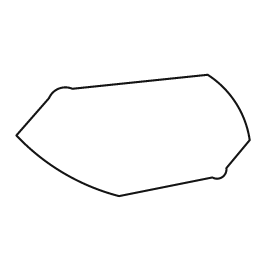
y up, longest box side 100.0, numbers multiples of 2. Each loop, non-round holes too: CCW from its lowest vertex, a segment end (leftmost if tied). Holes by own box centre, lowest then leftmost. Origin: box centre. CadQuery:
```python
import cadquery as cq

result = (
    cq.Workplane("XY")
    .moveTo(-6.0, -26.0)
    .lineTo(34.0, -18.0)
    .threePointArc((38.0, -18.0), (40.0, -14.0))
    .lineTo(50.0, -2.0)
    .threePointArc((44.0, 14.0), (32.0, 26.0))
    .lineTo(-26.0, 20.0)
    .threePointArc((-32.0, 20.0), (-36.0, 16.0))
    .lineTo(-50.0, 0.0)
    .threePointArc((-30.0, -16.0), (-6.0, -26.0))
    .close()
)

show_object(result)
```